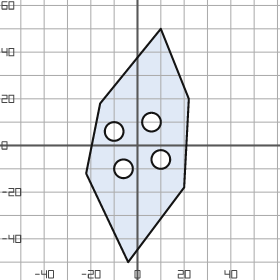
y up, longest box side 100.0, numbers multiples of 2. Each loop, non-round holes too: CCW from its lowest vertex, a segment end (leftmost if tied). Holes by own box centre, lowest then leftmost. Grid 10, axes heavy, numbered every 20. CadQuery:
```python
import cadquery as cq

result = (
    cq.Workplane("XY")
    .moveTo(-4.0, -50.0)
    .lineTo(20.0, -18.0)
    .lineTo(22.0, 20.0)
    .lineTo(10.0, 50.0)
    .lineTo(-16.0, 18.0)
    .lineTo(-22.0, -12.0)
    .close()
    .moveTo(-6.0, -10.0)
    .circle(4.0)
    .moveTo(10.0, -6.0)
    .circle(4.0)
    .moveTo(-10.0, 6.0)
    .circle(4.0)
    .moveTo(6.0, 10.0)
    .circle(4.0)
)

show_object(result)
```